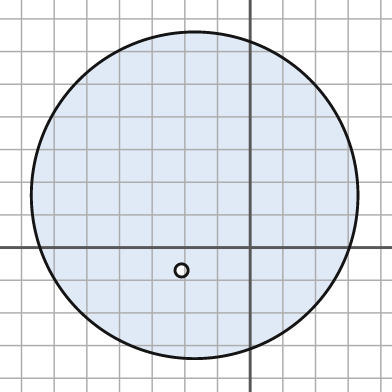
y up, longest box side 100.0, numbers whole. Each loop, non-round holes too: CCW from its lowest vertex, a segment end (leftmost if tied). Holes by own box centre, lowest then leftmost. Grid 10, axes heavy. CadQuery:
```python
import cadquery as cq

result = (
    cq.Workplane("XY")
    .moveTo(-17.0, 16.0)
    .circle(50.0)
    .moveTo(-21.0, -7.0)
    .circle(2.0)
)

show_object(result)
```